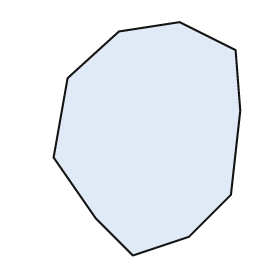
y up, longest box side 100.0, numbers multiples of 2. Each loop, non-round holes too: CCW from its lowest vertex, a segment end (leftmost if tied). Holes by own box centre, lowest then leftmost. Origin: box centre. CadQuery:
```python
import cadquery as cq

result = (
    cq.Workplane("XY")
    .moveTo(-6.0, -50.0)
    .lineTo(18.0, -42.0)
    .lineTo(36.0, -24.0)
    .lineTo(40.0, 12.0)
    .lineTo(38.0, 38.0)
    .lineTo(14.0, 50.0)
    .lineTo(-12.0, 46.0)
    .lineTo(-34.0, 26.0)
    .lineTo(-40.0, -8.0)
    .lineTo(-22.0, -34.0)
    .close()
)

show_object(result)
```